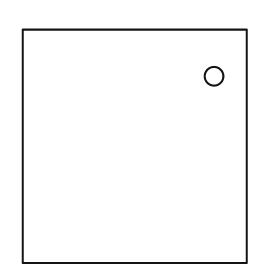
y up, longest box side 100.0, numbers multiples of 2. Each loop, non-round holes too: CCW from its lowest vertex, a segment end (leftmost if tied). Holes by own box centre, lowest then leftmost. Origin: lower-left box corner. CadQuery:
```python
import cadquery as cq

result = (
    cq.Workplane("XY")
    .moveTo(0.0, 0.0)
    .lineTo(96.0, 0.0)
    .lineTo(96.0, 100.0)
    .lineTo(0.0, 100.0)
    .close()
    .moveTo(82.0, 80.0)
    .circle(4.0)
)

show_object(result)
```